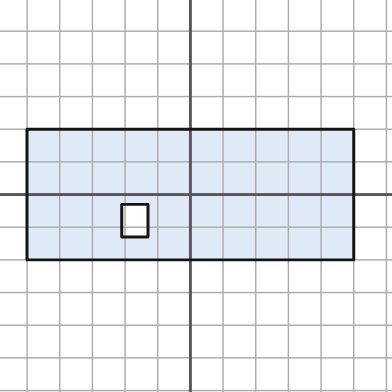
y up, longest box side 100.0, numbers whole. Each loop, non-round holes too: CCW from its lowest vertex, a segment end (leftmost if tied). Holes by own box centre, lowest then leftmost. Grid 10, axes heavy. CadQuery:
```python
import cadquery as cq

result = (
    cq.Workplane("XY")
    .moveTo(-50.0, -20.0)
    .lineTo(50.0, -20.0)
    .lineTo(50.0, 20.0)
    .lineTo(-50.0, 20.0)
    .close()
    .moveTo(-21.0, -13.0)
    .lineTo(-13.0, -13.0)
    .lineTo(-13.0, -3.0)
    .lineTo(-21.0, -3.0)
    .close()
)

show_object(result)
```